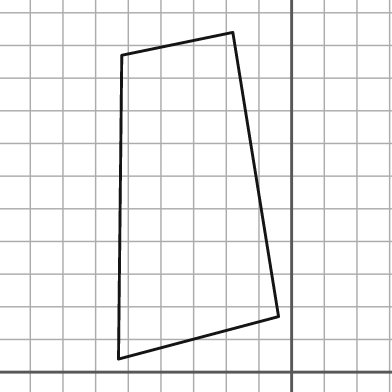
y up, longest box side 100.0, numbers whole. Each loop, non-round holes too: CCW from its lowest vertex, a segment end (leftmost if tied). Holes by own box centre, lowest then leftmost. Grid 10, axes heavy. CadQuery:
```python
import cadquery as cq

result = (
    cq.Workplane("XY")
    .moveTo(-53.0, 4.0)
    .lineTo(-4.0, 17.0)
    .lineTo(-18.0, 104.0)
    .lineTo(-52.0, 97.0)
    .close()
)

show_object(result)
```